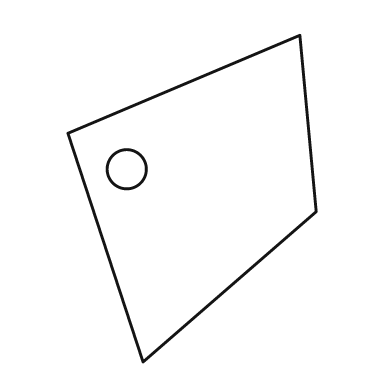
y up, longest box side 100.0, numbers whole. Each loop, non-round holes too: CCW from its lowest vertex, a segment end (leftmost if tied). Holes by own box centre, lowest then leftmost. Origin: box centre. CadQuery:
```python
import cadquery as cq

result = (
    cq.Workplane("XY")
    .moveTo(-15.0, -50.0)
    .lineTo(38.0, -4.0)
    .lineTo(33.0, 50.0)
    .lineTo(-38.0, 20.0)
    .close()
    .moveTo(-20.0, 9.0)
    .circle(6.0)
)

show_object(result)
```